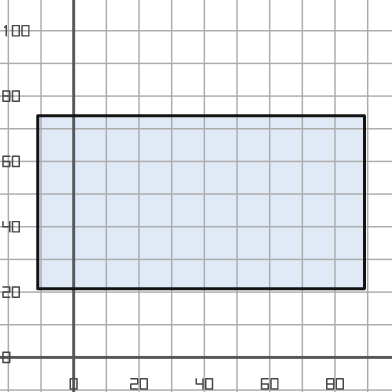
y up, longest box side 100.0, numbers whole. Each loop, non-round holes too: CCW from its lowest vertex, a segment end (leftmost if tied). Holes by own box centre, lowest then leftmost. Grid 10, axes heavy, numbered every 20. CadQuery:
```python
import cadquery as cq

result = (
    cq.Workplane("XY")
    .moveTo(-11.0, 21.0)
    .lineTo(89.0, 21.0)
    .lineTo(89.0, 74.0)
    .lineTo(-11.0, 74.0)
    .close()
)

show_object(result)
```